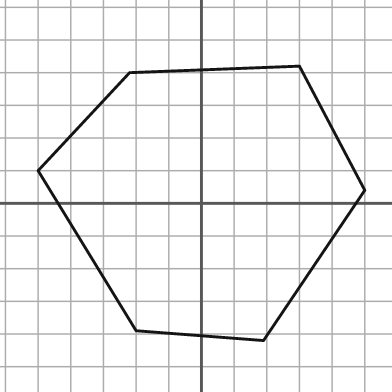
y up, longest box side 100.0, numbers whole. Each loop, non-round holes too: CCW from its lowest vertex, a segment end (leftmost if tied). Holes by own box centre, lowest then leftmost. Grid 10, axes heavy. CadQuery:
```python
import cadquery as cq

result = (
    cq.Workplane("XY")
    .moveTo(19.0, -42.0)
    .lineTo(50.0, 4.0)
    .lineTo(30.0, 42.0)
    .lineTo(-22.0, 40.0)
    .lineTo(-50.0, 10.0)
    .lineTo(-20.0, -39.0)
    .close()
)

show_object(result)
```